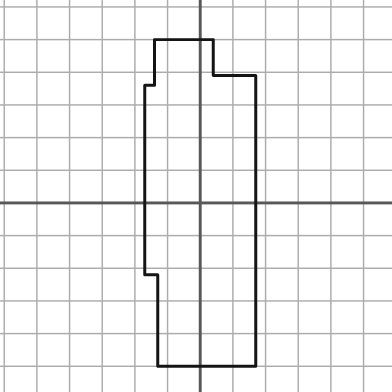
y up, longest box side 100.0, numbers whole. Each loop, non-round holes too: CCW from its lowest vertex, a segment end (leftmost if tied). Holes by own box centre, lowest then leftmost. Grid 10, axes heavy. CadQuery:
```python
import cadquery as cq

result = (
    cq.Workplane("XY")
    .moveTo(-13.0, -50.0)
    .lineTo(17.0, -50.0)
    .lineTo(17.0, 39.0)
    .lineTo(4.0, 39.0)
    .lineTo(4.0, 50.0)
    .lineTo(-14.0, 50.0)
    .lineTo(-14.0, 36.0)
    .lineTo(-17.0, 36.0)
    .lineTo(-17.0, -22.0)
    .lineTo(-13.0, -22.0)
    .close()
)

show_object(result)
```